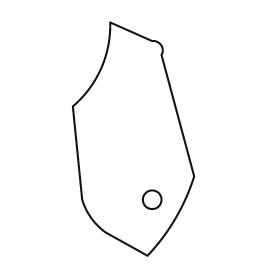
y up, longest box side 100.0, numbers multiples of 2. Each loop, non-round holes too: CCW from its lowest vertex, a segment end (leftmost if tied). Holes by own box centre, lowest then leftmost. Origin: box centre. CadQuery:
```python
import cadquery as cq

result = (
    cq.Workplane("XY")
    .moveTo(6.0, -50.0)
    .threePointArc((18.0, -34.0), (26.0, -16.0))
    .lineTo(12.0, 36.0)
    .threePointArc((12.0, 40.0), (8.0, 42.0))
    .lineTo(-10.0, 50.0)
    .threePointArc((-14.0, 30.0), (-26.0, 14.0))
    .lineTo(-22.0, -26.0)
    .threePointArc((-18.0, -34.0), (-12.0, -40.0))
    .close()
    .moveTo(8.0, -26.0)
    .circle(4.0)
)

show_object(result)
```